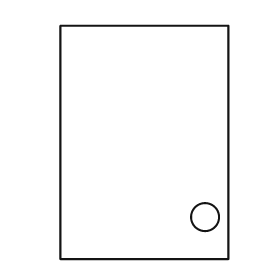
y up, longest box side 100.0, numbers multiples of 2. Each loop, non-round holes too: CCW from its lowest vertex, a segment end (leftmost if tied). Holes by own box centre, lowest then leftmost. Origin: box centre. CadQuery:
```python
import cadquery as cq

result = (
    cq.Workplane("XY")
    .moveTo(-36.0, -50.0)
    .lineTo(36.0, -50.0)
    .lineTo(36.0, 50.0)
    .lineTo(-36.0, 50.0)
    .close()
    .moveTo(26.0, -32.0)
    .circle(6.0)
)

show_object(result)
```